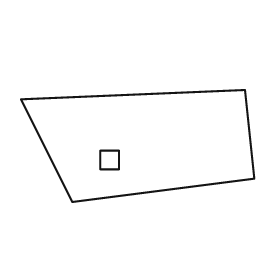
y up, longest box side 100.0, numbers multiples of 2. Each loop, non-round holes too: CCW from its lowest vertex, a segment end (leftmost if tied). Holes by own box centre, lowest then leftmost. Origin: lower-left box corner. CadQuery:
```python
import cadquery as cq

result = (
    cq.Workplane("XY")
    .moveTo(22.0, 0.0)
    .lineTo(100.0, 10.0)
    .lineTo(96.0, 48.0)
    .lineTo(0.0, 44.0)
    .close()
    .moveTo(34.0, 14.0)
    .lineTo(42.0, 14.0)
    .lineTo(42.0, 22.0)
    .lineTo(34.0, 22.0)
    .close()
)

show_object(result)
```